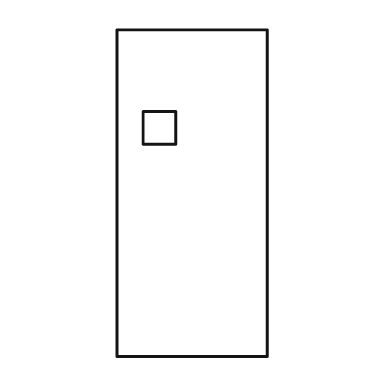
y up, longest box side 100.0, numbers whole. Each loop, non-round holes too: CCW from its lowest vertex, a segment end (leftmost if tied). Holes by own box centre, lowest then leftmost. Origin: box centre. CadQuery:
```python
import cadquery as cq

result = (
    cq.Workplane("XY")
    .moveTo(-23.0, -50.0)
    .lineTo(23.0, -50.0)
    .lineTo(23.0, 50.0)
    .lineTo(-23.0, 50.0)
    .close()
    .moveTo(-15.0, 15.0)
    .lineTo(-5.0, 15.0)
    .lineTo(-5.0, 25.0)
    .lineTo(-15.0, 25.0)
    .close()
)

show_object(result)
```